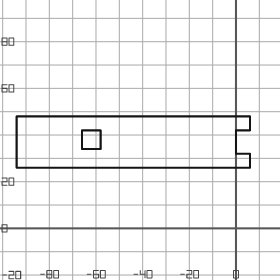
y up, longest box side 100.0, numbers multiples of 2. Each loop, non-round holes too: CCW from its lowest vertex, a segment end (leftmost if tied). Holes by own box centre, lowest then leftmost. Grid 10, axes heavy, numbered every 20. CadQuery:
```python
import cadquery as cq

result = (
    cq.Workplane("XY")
    .moveTo(-94.0, 26.0)
    .lineTo(6.0, 26.0)
    .lineTo(6.0, 32.0)
    .lineTo(0.0, 32.0)
    .lineTo(0.0, 42.0)
    .lineTo(6.0, 42.0)
    .lineTo(6.0, 48.0)
    .lineTo(-94.0, 48.0)
    .close()
    .moveTo(-66.0, 34.0)
    .lineTo(-58.0, 34.0)
    .lineTo(-58.0, 42.0)
    .lineTo(-66.0, 42.0)
    .close()
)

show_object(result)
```